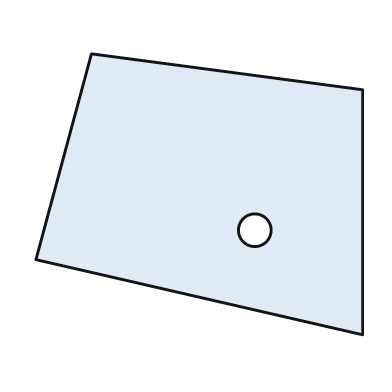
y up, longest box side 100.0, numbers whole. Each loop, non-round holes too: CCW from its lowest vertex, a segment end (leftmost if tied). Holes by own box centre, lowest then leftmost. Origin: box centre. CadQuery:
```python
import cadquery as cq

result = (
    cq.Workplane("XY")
    .moveTo(50.0, -43.0)
    .lineTo(50.0, 32.0)
    .lineTo(-33.0, 43.0)
    .lineTo(-50.0, -20.0)
    .close()
    .moveTo(17.0, -11.0)
    .circle(5.0)
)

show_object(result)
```